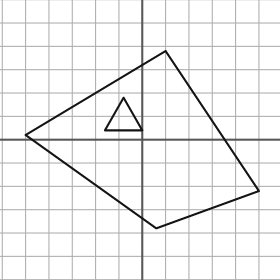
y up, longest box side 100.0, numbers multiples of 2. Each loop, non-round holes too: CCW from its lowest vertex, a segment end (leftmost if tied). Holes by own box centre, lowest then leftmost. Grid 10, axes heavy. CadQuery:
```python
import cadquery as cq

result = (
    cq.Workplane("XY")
    .moveTo(6.0, -38.0)
    .lineTo(50.0, -22.0)
    .lineTo(10.0, 38.0)
    .lineTo(-50.0, 2.0)
    .close()
    .moveTo(-16.0, 4.0)
    .lineTo(0.0, 4.0)
    .lineTo(-8.0, 18.0)
    .close()
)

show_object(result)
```